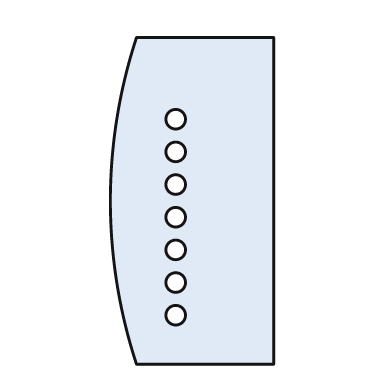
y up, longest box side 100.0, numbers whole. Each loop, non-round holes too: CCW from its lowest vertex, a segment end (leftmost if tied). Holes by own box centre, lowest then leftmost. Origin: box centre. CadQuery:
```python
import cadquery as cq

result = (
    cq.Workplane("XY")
    .moveTo(-17.0, -50.0)
    .lineTo(25.0, -50.0)
    .lineTo(25.0, 50.0)
    .lineTo(-17.0, 50.0)
    .threePointArc((-25.0, 0.0), (-17.0, -50.0))
    .close()
    .moveTo(-5.0, -35.0)
    .circle(3.0)
    .moveTo(-5.0, -25.0)
    .circle(3.0)
    .moveTo(-5.0, -15.0)
    .circle(3.0)
    .moveTo(-5.0, -5.0)
    .circle(3.0)
    .moveTo(-5.0, 5.0)
    .circle(3.0)
    .moveTo(-5.0, 15.0)
    .circle(3.0)
    .moveTo(-5.0, 25.0)
    .circle(3.0)
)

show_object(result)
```